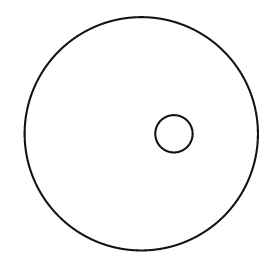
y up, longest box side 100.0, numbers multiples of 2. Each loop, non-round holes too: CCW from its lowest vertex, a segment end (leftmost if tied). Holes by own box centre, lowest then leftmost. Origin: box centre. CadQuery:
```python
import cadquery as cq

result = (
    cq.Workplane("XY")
    .moveTo(0.0, 0.0)
    .circle(50.0)
    .moveTo(14.0, 0.0)
    .circle(8.0)
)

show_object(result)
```